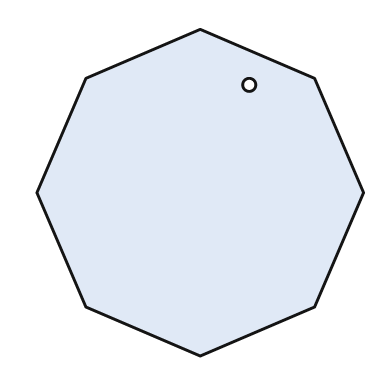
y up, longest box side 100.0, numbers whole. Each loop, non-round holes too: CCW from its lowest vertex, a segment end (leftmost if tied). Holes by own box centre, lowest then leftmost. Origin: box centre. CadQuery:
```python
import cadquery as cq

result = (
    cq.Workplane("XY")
    .moveTo(0.0, -50.0)
    .lineTo(35.0, -35.0)
    .lineTo(50.0, 0.0)
    .lineTo(35.0, 35.0)
    .lineTo(0.0, 50.0)
    .lineTo(-35.0, 35.0)
    .lineTo(-50.0, 0.0)
    .lineTo(-35.0, -35.0)
    .close()
    .moveTo(15.0, 33.0)
    .circle(2.0)
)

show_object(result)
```